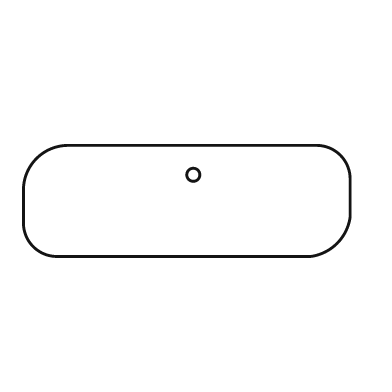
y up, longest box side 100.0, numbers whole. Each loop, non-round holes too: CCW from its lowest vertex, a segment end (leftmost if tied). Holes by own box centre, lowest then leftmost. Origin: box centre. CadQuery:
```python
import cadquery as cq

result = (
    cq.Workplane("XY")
    .moveTo(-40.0, -17.0)
    .lineTo(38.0, -17.0)
    .threePointArc((46.0, -13.0), (50.0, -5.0))
    .lineTo(50.0, 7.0)
    .threePointArc((47.0, 14.0), (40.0, 17.0))
    .lineTo(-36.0, 17.0)
    .threePointArc((-46.0, 13.0), (-50.0, 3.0))
    .lineTo(-50.0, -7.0)
    .threePointArc((-47.0, -14.0), (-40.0, -17.0))
    .close()
    .moveTo(2.0, 8.0)
    .circle(2.0)
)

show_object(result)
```